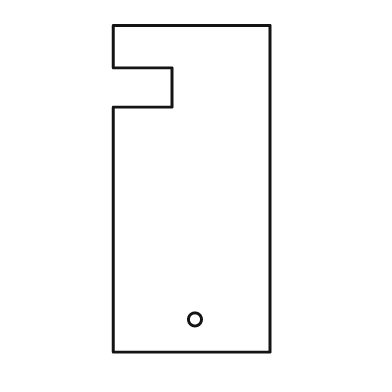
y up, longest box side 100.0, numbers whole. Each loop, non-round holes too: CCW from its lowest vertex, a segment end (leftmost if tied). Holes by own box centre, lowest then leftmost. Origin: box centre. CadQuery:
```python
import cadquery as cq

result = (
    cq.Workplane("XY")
    .moveTo(-24.0, -50.0)
    .lineTo(24.0, -50.0)
    .lineTo(24.0, 50.0)
    .lineTo(-24.0, 50.0)
    .lineTo(-24.0, 37.0)
    .lineTo(-6.0, 37.0)
    .lineTo(-6.0, 25.0)
    .lineTo(-24.0, 25.0)
    .close()
    .moveTo(1.0, -40.0)
    .circle(2.0)
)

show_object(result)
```